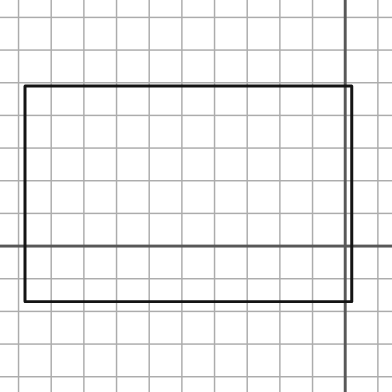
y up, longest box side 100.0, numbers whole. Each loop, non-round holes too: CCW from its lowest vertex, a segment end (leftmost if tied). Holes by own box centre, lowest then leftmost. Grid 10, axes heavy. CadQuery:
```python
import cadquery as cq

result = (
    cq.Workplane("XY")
    .moveTo(-98.0, -17.0)
    .lineTo(2.0, -17.0)
    .lineTo(2.0, 49.0)
    .lineTo(-98.0, 49.0)
    .close()
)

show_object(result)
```